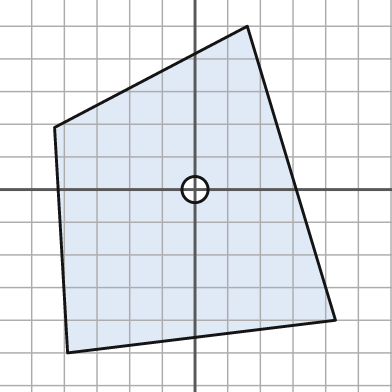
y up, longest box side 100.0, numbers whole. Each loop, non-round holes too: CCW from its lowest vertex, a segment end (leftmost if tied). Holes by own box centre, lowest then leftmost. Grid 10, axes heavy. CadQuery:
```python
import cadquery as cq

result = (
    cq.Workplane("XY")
    .moveTo(-39.0, -50.0)
    .lineTo(43.0, -40.0)
    .lineTo(16.0, 50.0)
    .lineTo(-43.0, 19.0)
    .close()
    .moveTo(0.0, 0.0)
    .circle(4.0)
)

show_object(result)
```